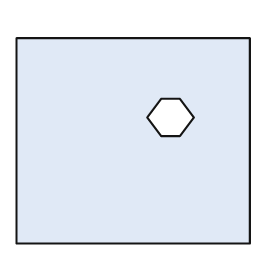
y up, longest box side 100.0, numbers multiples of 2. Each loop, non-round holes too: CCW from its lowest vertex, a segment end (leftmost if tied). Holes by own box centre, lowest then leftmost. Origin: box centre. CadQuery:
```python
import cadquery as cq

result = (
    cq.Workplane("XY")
    .moveTo(-50.0, -44.0)
    .lineTo(50.0, -44.0)
    .lineTo(50.0, 44.0)
    .lineTo(-50.0, 44.0)
    .close()
    .moveTo(12.0, 2.0)
    .lineTo(20.0, 2.0)
    .lineTo(26.0, 10.0)
    .lineTo(20.0, 18.0)
    .lineTo(12.0, 18.0)
    .lineTo(6.0, 10.0)
    .close()
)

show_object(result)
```